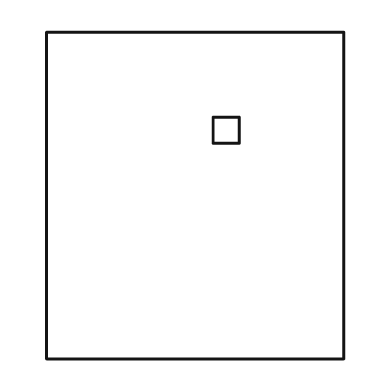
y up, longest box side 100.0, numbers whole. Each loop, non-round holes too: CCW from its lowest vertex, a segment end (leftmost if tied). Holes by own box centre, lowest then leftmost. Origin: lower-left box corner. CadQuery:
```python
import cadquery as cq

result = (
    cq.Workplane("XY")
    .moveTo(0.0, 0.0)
    .lineTo(91.0, 0.0)
    .lineTo(91.0, 100.0)
    .lineTo(0.0, 100.0)
    .close()
    .moveTo(51.0, 66.0)
    .lineTo(59.0, 66.0)
    .lineTo(59.0, 74.0)
    .lineTo(51.0, 74.0)
    .close()
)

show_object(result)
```